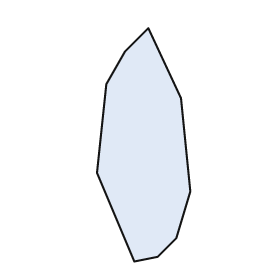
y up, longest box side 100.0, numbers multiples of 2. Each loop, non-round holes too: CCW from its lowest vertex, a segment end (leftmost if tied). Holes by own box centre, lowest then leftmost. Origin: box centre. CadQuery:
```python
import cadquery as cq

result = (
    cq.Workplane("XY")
    .moveTo(-4.0, -50.0)
    .lineTo(6.0, -48.0)
    .lineTo(14.0, -40.0)
    .lineTo(20.0, -20.0)
    .lineTo(16.0, 20.0)
    .lineTo(2.0, 50.0)
    .lineTo(-8.0, 40.0)
    .lineTo(-16.0, 26.0)
    .lineTo(-20.0, -12.0)
    .close()
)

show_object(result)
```